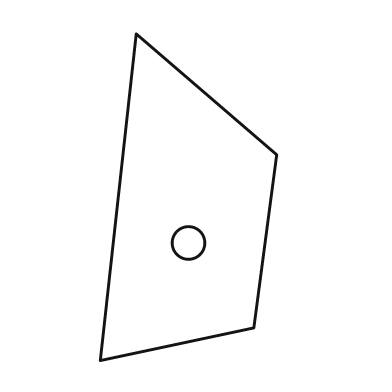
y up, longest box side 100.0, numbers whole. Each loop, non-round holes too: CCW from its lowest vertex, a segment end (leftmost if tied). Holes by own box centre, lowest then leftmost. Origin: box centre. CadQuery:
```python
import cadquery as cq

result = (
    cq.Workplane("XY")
    .moveTo(-27.0, -50.0)
    .lineTo(20.0, -40.0)
    .lineTo(27.0, 13.0)
    .lineTo(-16.0, 50.0)
    .close()
    .moveTo(0.0, -14.0)
    .circle(5.0)
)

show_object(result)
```